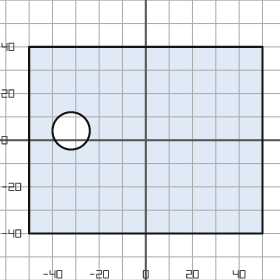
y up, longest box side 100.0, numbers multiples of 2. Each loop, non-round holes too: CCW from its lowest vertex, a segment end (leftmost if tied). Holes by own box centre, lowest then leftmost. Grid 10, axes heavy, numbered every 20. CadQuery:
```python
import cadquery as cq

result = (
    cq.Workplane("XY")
    .moveTo(-50.0, -40.0)
    .lineTo(50.0, -40.0)
    .lineTo(50.0, 40.0)
    .lineTo(-50.0, 40.0)
    .close()
    .moveTo(-32.0, 4.0)
    .circle(8.0)
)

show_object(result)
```